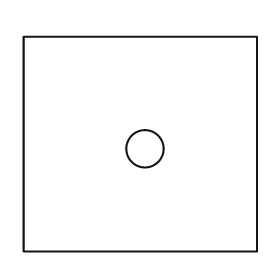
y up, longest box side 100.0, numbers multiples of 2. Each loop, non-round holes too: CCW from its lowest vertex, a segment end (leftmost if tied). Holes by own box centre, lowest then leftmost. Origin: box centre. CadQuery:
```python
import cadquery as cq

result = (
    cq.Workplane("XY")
    .moveTo(-50.0, -46.0)
    .lineTo(50.0, -46.0)
    .lineTo(50.0, 46.0)
    .lineTo(-50.0, 46.0)
    .close()
    .moveTo(2.0, -2.0)
    .circle(8.0)
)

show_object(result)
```